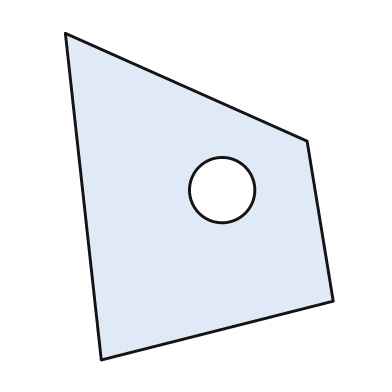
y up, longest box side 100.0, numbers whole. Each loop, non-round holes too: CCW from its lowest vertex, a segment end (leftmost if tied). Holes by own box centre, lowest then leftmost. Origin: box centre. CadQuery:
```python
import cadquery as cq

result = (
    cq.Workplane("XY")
    .moveTo(-30.0, -50.0)
    .lineTo(41.0, -32.0)
    .lineTo(33.0, 17.0)
    .lineTo(-41.0, 50.0)
    .close()
    .moveTo(7.0, 2.0)
    .circle(10.0)
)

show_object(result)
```